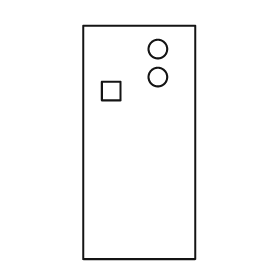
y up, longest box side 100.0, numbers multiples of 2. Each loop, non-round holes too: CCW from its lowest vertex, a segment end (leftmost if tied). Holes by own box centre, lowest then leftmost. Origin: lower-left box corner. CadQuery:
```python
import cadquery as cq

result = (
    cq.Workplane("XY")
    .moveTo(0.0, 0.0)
    .lineTo(48.0, 0.0)
    .lineTo(48.0, 100.0)
    .lineTo(0.0, 100.0)
    .close()
    .moveTo(8.0, 68.0)
    .lineTo(16.0, 68.0)
    .lineTo(16.0, 76.0)
    .lineTo(8.0, 76.0)
    .close()
    .moveTo(32.0, 78.0)
    .circle(4.0)
    .moveTo(32.0, 90.0)
    .circle(4.0)
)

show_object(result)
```